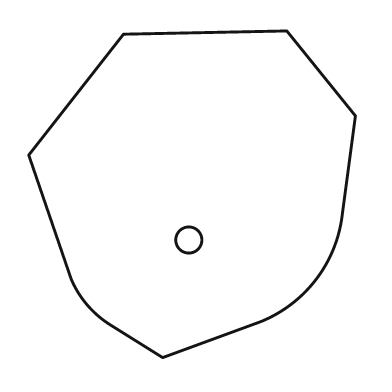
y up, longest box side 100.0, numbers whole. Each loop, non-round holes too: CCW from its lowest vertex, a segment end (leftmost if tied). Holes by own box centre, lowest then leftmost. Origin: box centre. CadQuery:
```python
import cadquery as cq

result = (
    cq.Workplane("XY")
    .moveTo(-9.0, -50.0)
    .lineTo(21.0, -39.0)
    .threePointArc((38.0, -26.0), (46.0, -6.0))
    .lineTo(50.0, 24.0)
    .lineTo(29.0, 50.0)
    .lineTo(-21.0, 49.0)
    .lineTo(-50.0, 12.0)
    .lineTo(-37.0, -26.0)
    .threePointArc((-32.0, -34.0), (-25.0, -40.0))
    .close()
    .moveTo(-1.0, -14.0)
    .circle(4.0)
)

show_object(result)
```